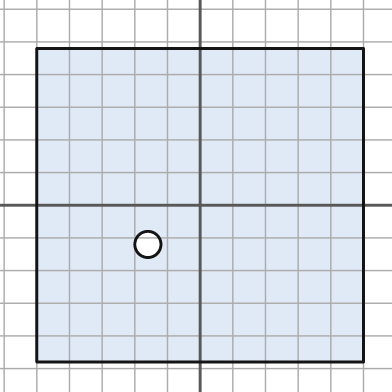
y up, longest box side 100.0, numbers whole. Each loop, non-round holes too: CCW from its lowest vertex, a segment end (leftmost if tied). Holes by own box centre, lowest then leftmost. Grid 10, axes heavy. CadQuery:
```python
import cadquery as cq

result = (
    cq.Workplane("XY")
    .moveTo(-50.0, -48.0)
    .lineTo(50.0, -48.0)
    .lineTo(50.0, 48.0)
    .lineTo(-50.0, 48.0)
    .close()
    .moveTo(-16.0, -12.0)
    .circle(4.0)
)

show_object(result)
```